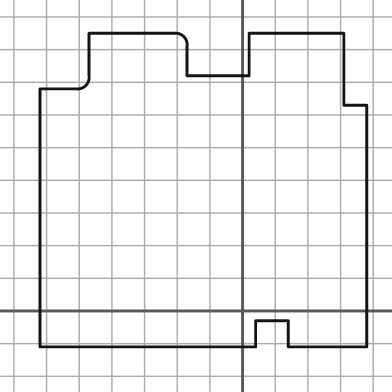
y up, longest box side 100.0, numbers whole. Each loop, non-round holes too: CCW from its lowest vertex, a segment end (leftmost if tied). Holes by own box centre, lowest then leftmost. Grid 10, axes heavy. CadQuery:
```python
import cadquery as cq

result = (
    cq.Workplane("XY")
    .moveTo(-62.0, -11.0)
    .lineTo(4.0, -11.0)
    .lineTo(4.0, -3.0)
    .lineTo(14.0, -3.0)
    .lineTo(14.0, -11.0)
    .lineTo(38.0, -11.0)
    .lineTo(38.0, 63.0)
    .lineTo(31.0, 63.0)
    .lineTo(31.0, 85.0)
    .lineTo(2.0, 85.0)
    .lineTo(2.0, 72.0)
    .lineTo(-17.0, 72.0)
    .lineTo(-17.0, 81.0)
    .threePointArc((-18.0, 84.0), (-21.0, 85.0))
    .lineTo(-47.0, 85.0)
    .lineTo(-47.0, 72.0)
    .threePointArc((-48.0, 69.0), (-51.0, 68.0))
    .lineTo(-62.0, 68.0)
    .close()
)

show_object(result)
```